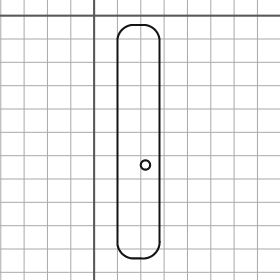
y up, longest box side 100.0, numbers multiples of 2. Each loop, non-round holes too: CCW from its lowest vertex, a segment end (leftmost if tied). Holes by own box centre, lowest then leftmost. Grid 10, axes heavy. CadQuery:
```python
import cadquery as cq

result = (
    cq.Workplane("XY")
    .moveTo(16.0, -104.0)
    .lineTo(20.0, -104.0)
    .threePointArc((26.0, -102.0), (28.0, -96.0))
    .lineTo(28.0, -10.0)
    .threePointArc((26.0, -6.0), (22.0, -4.0))
    .lineTo(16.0, -4.0)
    .threePointArc((12.0, -6.0), (10.0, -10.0))
    .lineTo(10.0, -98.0)
    .threePointArc((12.0, -102.0), (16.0, -104.0))
    .close()
    .moveTo(22.0, -64.0)
    .circle(2.0)
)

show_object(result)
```